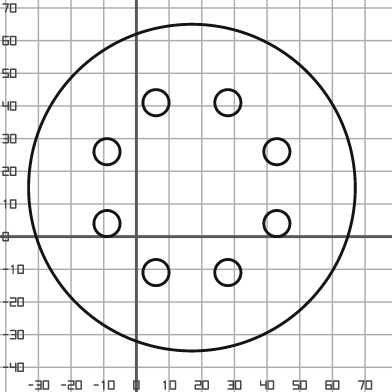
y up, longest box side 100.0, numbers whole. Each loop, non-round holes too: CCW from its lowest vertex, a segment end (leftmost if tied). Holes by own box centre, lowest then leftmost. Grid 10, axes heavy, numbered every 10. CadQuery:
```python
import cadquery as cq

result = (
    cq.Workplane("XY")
    .moveTo(17.0, 15.0)
    .circle(50.0)
    .moveTo(6.0, -11.0)
    .circle(4.0)
    .moveTo(28.0, -11.0)
    .circle(4.0)
    .moveTo(-9.0, 4.0)
    .circle(4.0)
    .moveTo(43.0, 4.0)
    .circle(4.0)
    .moveTo(-9.0, 26.0)
    .circle(4.0)
    .moveTo(43.0, 26.0)
    .circle(4.0)
    .moveTo(6.0, 41.0)
    .circle(4.0)
    .moveTo(28.0, 41.0)
    .circle(4.0)
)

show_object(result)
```